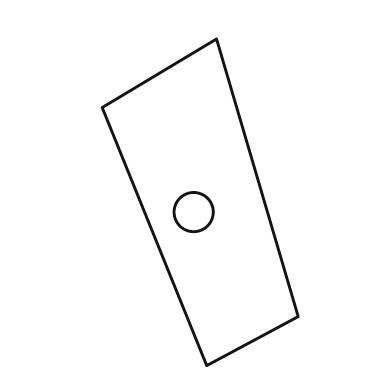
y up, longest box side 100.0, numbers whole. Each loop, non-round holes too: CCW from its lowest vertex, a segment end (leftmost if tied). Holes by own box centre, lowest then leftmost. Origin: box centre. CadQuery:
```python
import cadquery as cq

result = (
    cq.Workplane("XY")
    .moveTo(2.0, -50.0)
    .lineTo(30.0, -35.0)
    .lineTo(5.0, 50.0)
    .lineTo(-30.0, 29.0)
    .close()
    .moveTo(-2.0, -3.0)
    .circle(6.0)
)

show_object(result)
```